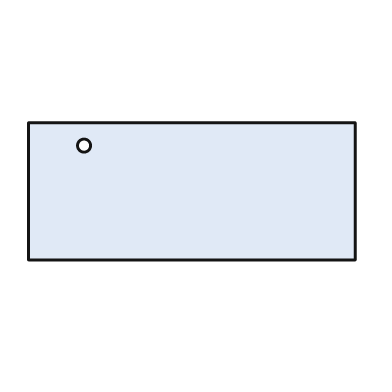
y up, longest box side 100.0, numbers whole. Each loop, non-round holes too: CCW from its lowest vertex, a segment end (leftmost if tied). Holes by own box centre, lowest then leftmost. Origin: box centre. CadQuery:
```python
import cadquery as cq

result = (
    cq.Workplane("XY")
    .moveTo(-50.0, -21.0)
    .lineTo(50.0, -21.0)
    .lineTo(50.0, 21.0)
    .lineTo(-50.0, 21.0)
    .close()
    .moveTo(-33.0, 14.0)
    .circle(2.0)
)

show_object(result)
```